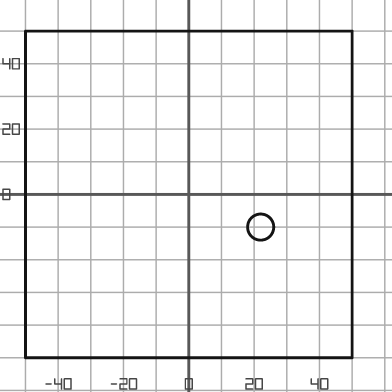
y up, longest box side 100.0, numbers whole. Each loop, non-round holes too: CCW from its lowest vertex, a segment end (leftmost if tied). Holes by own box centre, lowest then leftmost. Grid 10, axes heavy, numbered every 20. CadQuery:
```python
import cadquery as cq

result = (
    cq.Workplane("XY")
    .moveTo(-50.0, -50.0)
    .lineTo(50.0, -50.0)
    .lineTo(50.0, 50.0)
    .lineTo(-50.0, 50.0)
    .close()
    .moveTo(22.0, -10.0)
    .circle(4.0)
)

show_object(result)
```